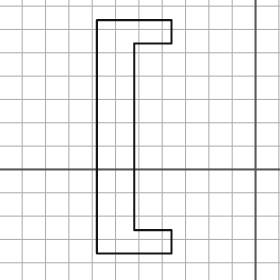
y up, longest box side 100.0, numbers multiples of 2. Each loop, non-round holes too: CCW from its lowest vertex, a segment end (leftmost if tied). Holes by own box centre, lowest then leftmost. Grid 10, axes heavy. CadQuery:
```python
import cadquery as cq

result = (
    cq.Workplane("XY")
    .moveTo(-68.0, -36.0)
    .lineTo(-36.0, -36.0)
    .lineTo(-36.0, -26.0)
    .lineTo(-52.0, -26.0)
    .lineTo(-52.0, 54.0)
    .lineTo(-36.0, 54.0)
    .lineTo(-36.0, 64.0)
    .lineTo(-68.0, 64.0)
    .close()
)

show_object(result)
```